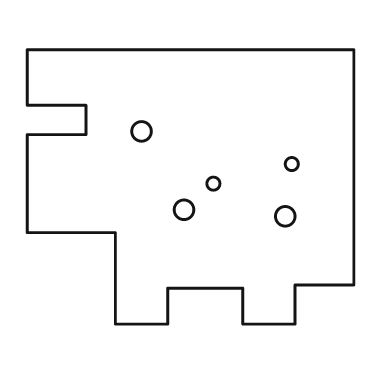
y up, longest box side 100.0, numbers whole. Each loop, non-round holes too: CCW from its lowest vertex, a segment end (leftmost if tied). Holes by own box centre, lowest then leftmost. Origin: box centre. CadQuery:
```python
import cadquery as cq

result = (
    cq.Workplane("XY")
    .moveTo(-23.0, -42.0)
    .lineTo(-7.0, -42.0)
    .lineTo(-7.0, -31.0)
    .lineTo(16.0, -31.0)
    .lineTo(16.0, -42.0)
    .lineTo(32.0, -42.0)
    .lineTo(32.0, -30.0)
    .lineTo(50.0, -30.0)
    .lineTo(50.0, 42.0)
    .lineTo(-50.0, 42.0)
    .lineTo(-50.0, 25.0)
    .lineTo(-32.0, 25.0)
    .lineTo(-32.0, 16.0)
    .lineTo(-50.0, 16.0)
    .lineTo(-50.0, -14.0)
    .lineTo(-23.0, -14.0)
    .close()
    .moveTo(29.0, -9.0)
    .circle(3.0)
    .moveTo(-2.0, -7.0)
    .circle(3.0)
    .moveTo(7.0, 1.0)
    .circle(2.0)
    .moveTo(31.0, 7.0)
    .circle(2.0)
    .moveTo(-15.0, 17.0)
    .circle(3.0)
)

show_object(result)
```